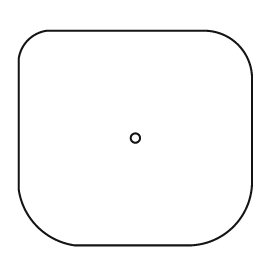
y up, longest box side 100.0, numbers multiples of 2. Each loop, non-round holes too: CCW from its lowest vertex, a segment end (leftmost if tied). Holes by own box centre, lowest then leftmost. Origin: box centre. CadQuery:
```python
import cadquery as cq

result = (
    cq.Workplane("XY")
    .moveTo(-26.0, -46.0)
    .lineTo(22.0, -46.0)
    .threePointArc((42.0, -38.0), (50.0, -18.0))
    .lineTo(50.0, 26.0)
    .threePointArc((44.0, 40.0), (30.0, 46.0))
    .lineTo(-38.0, 46.0)
    .threePointArc((-46.0, 42.0), (-50.0, 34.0))
    .lineTo(-50.0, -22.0)
    .threePointArc((-42.0, -38.0), (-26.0, -46.0))
    .close()
    .moveTo(0.0, 0.0)
    .circle(2.0)
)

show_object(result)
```